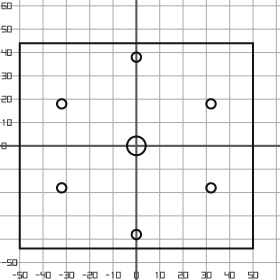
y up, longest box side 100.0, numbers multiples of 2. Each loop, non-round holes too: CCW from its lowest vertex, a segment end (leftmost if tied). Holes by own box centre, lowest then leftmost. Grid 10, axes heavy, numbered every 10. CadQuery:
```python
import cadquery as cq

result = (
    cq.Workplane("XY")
    .moveTo(-50.0, -44.0)
    .lineTo(50.0, -44.0)
    .lineTo(50.0, 44.0)
    .lineTo(-50.0, 44.0)
    .close()
    .moveTo(0.0, -38.0)
    .circle(2.0)
    .moveTo(-32.0, -18.0)
    .circle(2.0)
    .moveTo(32.0, -18.0)
    .circle(2.0)
    .moveTo(0.0, 0.0)
    .circle(4.0)
    .moveTo(-32.0, 18.0)
    .circle(2.0)
    .moveTo(32.0, 18.0)
    .circle(2.0)
    .moveTo(0.0, 38.0)
    .circle(2.0)
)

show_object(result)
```